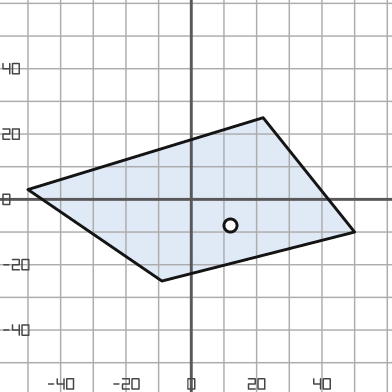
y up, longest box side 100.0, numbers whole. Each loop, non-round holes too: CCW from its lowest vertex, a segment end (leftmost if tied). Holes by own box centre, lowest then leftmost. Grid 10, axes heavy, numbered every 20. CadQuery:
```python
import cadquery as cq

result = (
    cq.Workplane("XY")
    .moveTo(-9.0, -25.0)
    .lineTo(50.0, -10.0)
    .lineTo(22.0, 25.0)
    .lineTo(-50.0, 3.0)
    .close()
    .moveTo(12.0, -8.0)
    .circle(2.0)
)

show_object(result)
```